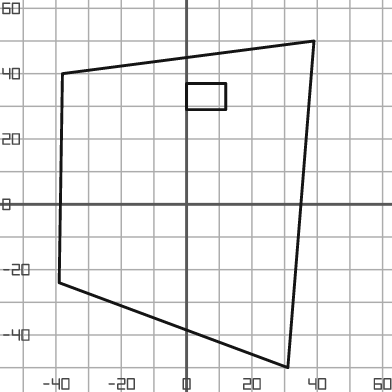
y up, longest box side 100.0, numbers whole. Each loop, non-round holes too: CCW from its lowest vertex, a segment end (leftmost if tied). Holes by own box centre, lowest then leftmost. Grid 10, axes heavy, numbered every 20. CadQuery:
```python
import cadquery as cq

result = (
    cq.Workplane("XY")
    .moveTo(31.0, -50.0)
    .lineTo(39.0, 50.0)
    .lineTo(-38.0, 40.0)
    .lineTo(-39.0, -24.0)
    .close()
    .moveTo(0.0, 29.0)
    .lineTo(12.0, 29.0)
    .lineTo(12.0, 37.0)
    .lineTo(0.0, 37.0)
    .close()
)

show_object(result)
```